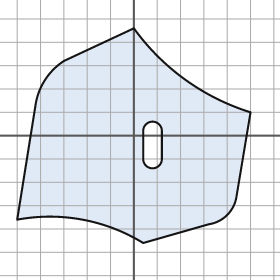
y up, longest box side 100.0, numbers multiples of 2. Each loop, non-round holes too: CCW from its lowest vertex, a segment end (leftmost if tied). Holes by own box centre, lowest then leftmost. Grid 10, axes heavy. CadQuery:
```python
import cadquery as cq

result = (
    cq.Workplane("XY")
    .moveTo(4.0, -46.0)
    .lineTo(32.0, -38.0)
    .threePointArc((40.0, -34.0), (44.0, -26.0))
    .lineTo(50.0, 10.0)
    .threePointArc((22.0, 24.0), (0.0, 46.0))
    .lineTo(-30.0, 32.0)
    .threePointArc((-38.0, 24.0), (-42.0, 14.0))
    .lineTo(-50.0, -36.0)
    .threePointArc((-22.0, -36.0), (4.0, -46.0))
    .close()
    .moveTo(4.0, -10.0)
    .threePointArc((8.0, -14.0), (12.0, -10.0))
    .lineTo(12.0, 2.0)
    .threePointArc((8.0, 6.0), (4.0, 2.0))
    .close()
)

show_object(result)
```